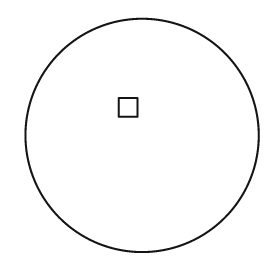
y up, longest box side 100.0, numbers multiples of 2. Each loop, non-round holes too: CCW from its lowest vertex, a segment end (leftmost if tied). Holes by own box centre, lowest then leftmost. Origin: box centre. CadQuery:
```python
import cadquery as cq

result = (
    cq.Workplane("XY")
    .moveTo(0.0, 0.0)
    .circle(50.0)
    .moveTo(-10.0, 8.0)
    .lineTo(-2.0, 8.0)
    .lineTo(-2.0, 16.0)
    .lineTo(-10.0, 16.0)
    .close()
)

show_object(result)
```